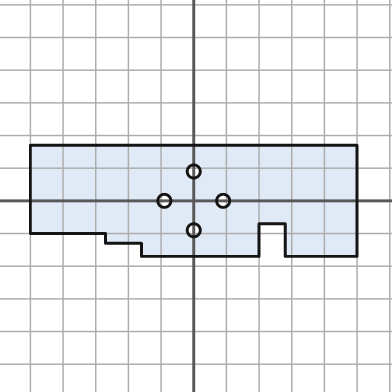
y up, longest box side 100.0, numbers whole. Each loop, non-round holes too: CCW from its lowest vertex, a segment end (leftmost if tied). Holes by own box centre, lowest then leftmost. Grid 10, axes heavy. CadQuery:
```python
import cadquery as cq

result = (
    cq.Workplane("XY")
    .moveTo(-16.0, -17.0)
    .lineTo(20.0, -17.0)
    .lineTo(20.0, -7.0)
    .lineTo(28.0, -7.0)
    .lineTo(28.0, -17.0)
    .lineTo(50.0, -17.0)
    .lineTo(50.0, 17.0)
    .lineTo(-50.0, 17.0)
    .lineTo(-50.0, -10.0)
    .lineTo(-27.0, -10.0)
    .lineTo(-27.0, -13.0)
    .lineTo(-16.0, -13.0)
    .close()
    .moveTo(0.0, -9.0)
    .circle(2.0)
    .moveTo(-9.0, 0.0)
    .circle(2.0)
    .moveTo(9.0, 0.0)
    .circle(2.0)
    .moveTo(0.0, 9.0)
    .circle(2.0)
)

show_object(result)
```